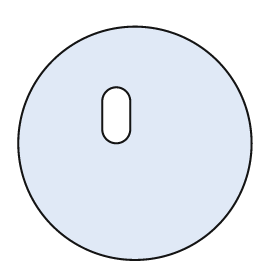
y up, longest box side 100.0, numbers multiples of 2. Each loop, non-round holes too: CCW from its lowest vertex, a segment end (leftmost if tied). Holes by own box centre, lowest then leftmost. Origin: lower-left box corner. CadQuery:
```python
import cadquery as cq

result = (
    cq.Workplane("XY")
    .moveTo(50.0, 50.0)
    .circle(50.0)
    .moveTo(36.0, 56.0)
    .threePointArc((42.0, 50.0), (48.0, 56.0))
    .lineTo(48.0, 68.0)
    .threePointArc((42.0, 74.0), (36.0, 68.0))
    .close()
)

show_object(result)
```